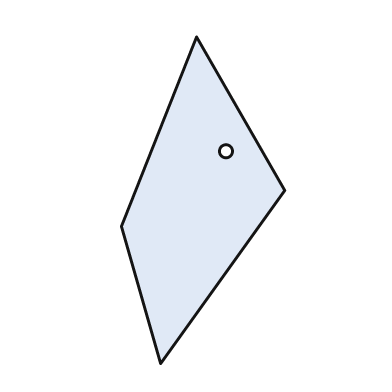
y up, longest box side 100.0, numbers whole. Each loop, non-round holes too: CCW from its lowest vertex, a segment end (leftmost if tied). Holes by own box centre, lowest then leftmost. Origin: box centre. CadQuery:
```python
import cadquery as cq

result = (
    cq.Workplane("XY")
    .moveTo(-13.0, -50.0)
    .lineTo(25.0, 3.0)
    .lineTo(-2.0, 50.0)
    .lineTo(-25.0, -8.0)
    .close()
    .moveTo(7.0, 15.0)
    .circle(2.0)
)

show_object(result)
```